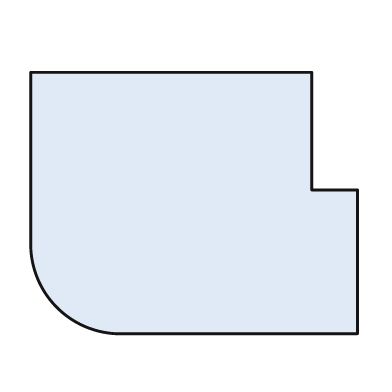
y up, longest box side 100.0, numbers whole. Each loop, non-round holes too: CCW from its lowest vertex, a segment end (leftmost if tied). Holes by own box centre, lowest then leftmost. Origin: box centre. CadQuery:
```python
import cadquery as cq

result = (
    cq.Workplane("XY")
    .moveTo(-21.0, -40.0)
    .lineTo(50.0, -40.0)
    .lineTo(50.0, 4.0)
    .lineTo(36.0, 4.0)
    .lineTo(36.0, 40.0)
    .lineTo(-50.0, 40.0)
    .lineTo(-50.0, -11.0)
    .threePointArc((-42.0, -32.0), (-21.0, -40.0))
    .close()
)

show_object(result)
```